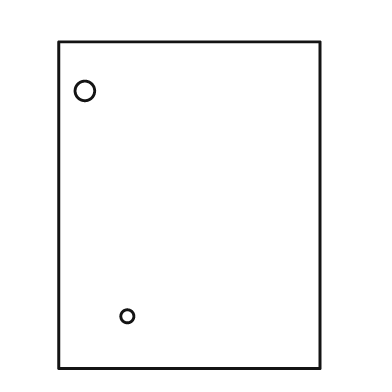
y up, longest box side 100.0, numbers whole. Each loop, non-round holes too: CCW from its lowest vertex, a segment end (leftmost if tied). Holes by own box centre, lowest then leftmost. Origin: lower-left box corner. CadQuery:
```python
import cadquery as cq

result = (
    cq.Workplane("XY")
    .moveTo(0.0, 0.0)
    .lineTo(80.0, 0.0)
    .lineTo(80.0, 100.0)
    .lineTo(0.0, 100.0)
    .close()
    .moveTo(21.0, 16.0)
    .circle(2.0)
    .moveTo(8.0, 85.0)
    .circle(3.0)
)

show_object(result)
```